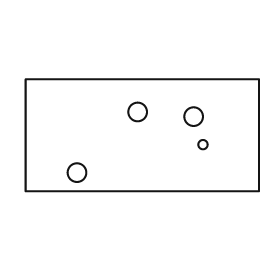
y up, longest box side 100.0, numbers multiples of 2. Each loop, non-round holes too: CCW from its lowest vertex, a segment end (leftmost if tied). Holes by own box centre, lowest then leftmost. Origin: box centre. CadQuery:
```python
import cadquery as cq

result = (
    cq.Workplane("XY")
    .moveTo(-50.0, -24.0)
    .lineTo(50.0, -24.0)
    .lineTo(50.0, 24.0)
    .lineTo(-50.0, 24.0)
    .close()
    .moveTo(-28.0, -16.0)
    .circle(4.0)
    .moveTo(26.0, -4.0)
    .circle(2.0)
    .moveTo(22.0, 8.0)
    .circle(4.0)
    .moveTo(-2.0, 10.0)
    .circle(4.0)
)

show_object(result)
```